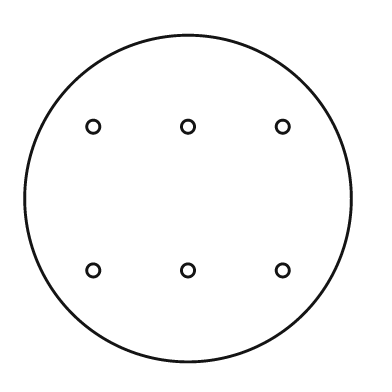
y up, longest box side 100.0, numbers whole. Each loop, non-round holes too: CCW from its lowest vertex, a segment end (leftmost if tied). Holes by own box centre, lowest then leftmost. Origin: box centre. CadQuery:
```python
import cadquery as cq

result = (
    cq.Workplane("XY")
    .moveTo(0.0, 0.0)
    .circle(50.0)
    .moveTo(-29.0, -22.0)
    .circle(2.0)
    .moveTo(0.0, -22.0)
    .circle(2.0)
    .moveTo(29.0, -22.0)
    .circle(2.0)
    .moveTo(-29.0, 22.0)
    .circle(2.0)
    .moveTo(0.0, 22.0)
    .circle(2.0)
    .moveTo(29.0, 22.0)
    .circle(2.0)
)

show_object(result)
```